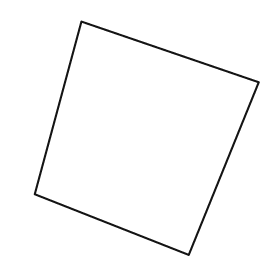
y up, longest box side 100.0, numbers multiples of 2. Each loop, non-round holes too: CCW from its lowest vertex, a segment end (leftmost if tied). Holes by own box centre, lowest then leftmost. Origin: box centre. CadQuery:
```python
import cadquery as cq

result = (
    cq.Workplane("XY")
    .moveTo(18.0, -50.0)
    .lineTo(48.0, 24.0)
    .lineTo(-28.0, 50.0)
    .lineTo(-48.0, -24.0)
    .close()
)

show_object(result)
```